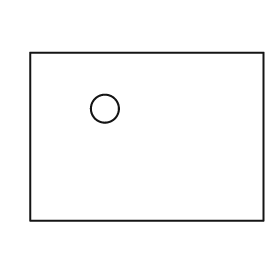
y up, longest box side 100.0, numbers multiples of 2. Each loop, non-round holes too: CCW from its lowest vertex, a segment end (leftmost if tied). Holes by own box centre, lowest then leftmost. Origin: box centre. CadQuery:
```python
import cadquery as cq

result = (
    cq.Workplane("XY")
    .moveTo(-50.0, -36.0)
    .lineTo(50.0, -36.0)
    .lineTo(50.0, 36.0)
    .lineTo(-50.0, 36.0)
    .close()
    .moveTo(-18.0, 12.0)
    .circle(6.0)
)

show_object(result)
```